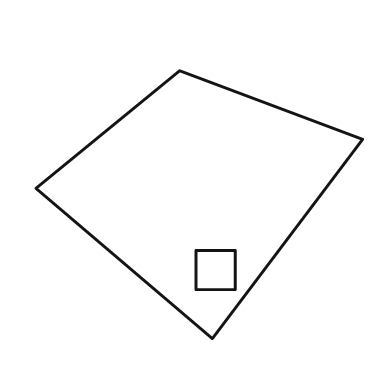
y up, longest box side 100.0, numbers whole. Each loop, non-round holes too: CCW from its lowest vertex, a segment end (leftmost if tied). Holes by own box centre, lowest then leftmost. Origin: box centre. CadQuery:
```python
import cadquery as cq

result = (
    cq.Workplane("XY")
    .moveTo(4.0, -41.0)
    .lineTo(50.0, 20.0)
    .lineTo(-6.0, 41.0)
    .lineTo(-50.0, 5.0)
    .close()
    .moveTo(-1.0, -26.0)
    .lineTo(11.0, -26.0)
    .lineTo(11.0, -14.0)
    .lineTo(-1.0, -14.0)
    .close()
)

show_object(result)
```